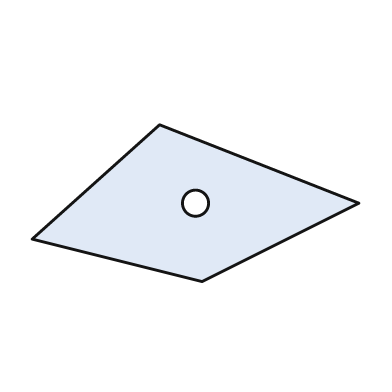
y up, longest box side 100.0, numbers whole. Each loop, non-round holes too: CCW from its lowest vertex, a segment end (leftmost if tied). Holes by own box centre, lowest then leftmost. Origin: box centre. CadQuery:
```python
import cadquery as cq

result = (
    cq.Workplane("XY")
    .moveTo(2.0, -24.0)
    .lineTo(50.0, 0.0)
    .lineTo(-11.0, 24.0)
    .lineTo(-50.0, -11.0)
    .close()
    .moveTo(0.0, 0.0)
    .circle(4.0)
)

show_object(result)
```